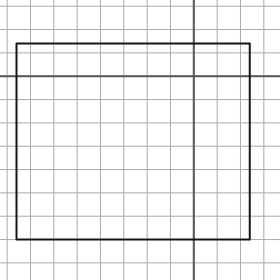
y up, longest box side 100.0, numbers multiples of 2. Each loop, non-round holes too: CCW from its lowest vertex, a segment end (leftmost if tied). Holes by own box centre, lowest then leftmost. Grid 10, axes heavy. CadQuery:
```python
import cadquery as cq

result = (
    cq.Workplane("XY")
    .moveTo(-76.0, -70.0)
    .lineTo(24.0, -70.0)
    .lineTo(24.0, 14.0)
    .lineTo(-76.0, 14.0)
    .close()
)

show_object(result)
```